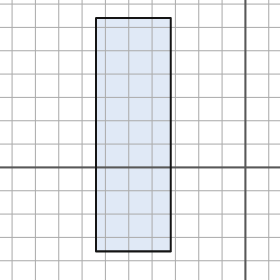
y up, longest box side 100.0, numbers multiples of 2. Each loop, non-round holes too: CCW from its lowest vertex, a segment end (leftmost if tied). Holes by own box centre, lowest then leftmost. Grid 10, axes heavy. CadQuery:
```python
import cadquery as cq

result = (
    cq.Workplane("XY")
    .moveTo(-64.0, -36.0)
    .lineTo(-32.0, -36.0)
    .lineTo(-32.0, 64.0)
    .lineTo(-64.0, 64.0)
    .close()
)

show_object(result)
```